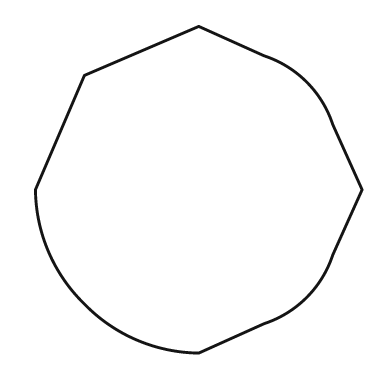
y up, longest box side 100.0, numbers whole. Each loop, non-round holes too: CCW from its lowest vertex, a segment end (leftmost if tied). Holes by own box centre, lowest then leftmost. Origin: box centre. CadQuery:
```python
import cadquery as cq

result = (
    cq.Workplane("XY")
    .moveTo(0.0, -50.0)
    .lineTo(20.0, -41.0)
    .threePointArc((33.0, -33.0), (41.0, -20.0))
    .lineTo(50.0, 0.0)
    .lineTo(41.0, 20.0)
    .threePointArc((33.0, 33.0), (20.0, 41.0))
    .lineTo(0.0, 50.0)
    .lineTo(-35.0, 35.0)
    .lineTo(-50.0, 0.0)
    .threePointArc((-46.0, -19.0), (-35.0, -35.0))
    .threePointArc((-19.0, -46.0), (0.0, -50.0))
    .close()
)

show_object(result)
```